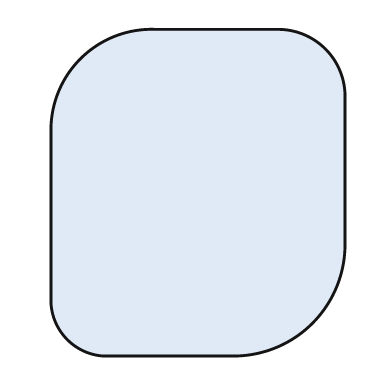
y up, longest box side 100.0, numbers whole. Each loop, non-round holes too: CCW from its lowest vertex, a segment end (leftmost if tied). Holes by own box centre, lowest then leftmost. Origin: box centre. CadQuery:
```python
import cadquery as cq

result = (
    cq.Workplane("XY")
    .moveTo(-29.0, -50.0)
    .lineTo(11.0, -50.0)
    .threePointArc((35.0, -40.0), (45.0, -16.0))
    .lineTo(45.0, 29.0)
    .threePointArc((39.0, 44.0), (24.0, 50.0))
    .lineTo(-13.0, 50.0)
    .threePointArc((-36.0, 41.0), (-45.0, 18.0))
    .lineTo(-45.0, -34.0)
    .threePointArc((-40.0, -45.0), (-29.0, -50.0))
    .close()
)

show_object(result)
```